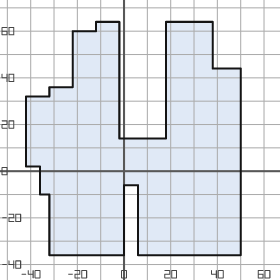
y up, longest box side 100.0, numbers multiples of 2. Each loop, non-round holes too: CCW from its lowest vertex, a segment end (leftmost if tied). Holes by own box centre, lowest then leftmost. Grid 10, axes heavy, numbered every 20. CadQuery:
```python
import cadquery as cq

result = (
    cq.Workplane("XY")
    .moveTo(-32.0, -36.0)
    .lineTo(0.0, -36.0)
    .lineTo(0.0, -6.0)
    .lineTo(6.0, -6.0)
    .lineTo(6.0, -36.0)
    .lineTo(50.0, -36.0)
    .lineTo(50.0, 44.0)
    .lineTo(38.0, 44.0)
    .lineTo(38.0, 64.0)
    .lineTo(18.0, 64.0)
    .lineTo(18.0, 14.0)
    .lineTo(-2.0, 14.0)
    .lineTo(-2.0, 64.0)
    .lineTo(-12.0, 64.0)
    .lineTo(-12.0, 60.0)
    .lineTo(-22.0, 60.0)
    .lineTo(-22.0, 36.0)
    .lineTo(-32.0, 36.0)
    .lineTo(-32.0, 32.0)
    .lineTo(-42.0, 32.0)
    .lineTo(-42.0, 2.0)
    .lineTo(-36.0, 2.0)
    .lineTo(-36.0, -10.0)
    .lineTo(-32.0, -10.0)
    .close()
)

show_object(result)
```